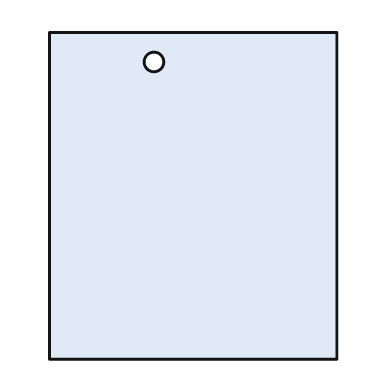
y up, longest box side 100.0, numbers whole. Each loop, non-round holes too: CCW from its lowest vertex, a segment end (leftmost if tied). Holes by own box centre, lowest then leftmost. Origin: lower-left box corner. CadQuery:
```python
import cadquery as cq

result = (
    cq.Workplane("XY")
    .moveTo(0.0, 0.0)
    .lineTo(88.0, 0.0)
    .lineTo(88.0, 100.0)
    .lineTo(0.0, 100.0)
    .close()
    .moveTo(32.0, 91.0)
    .circle(3.0)
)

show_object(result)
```